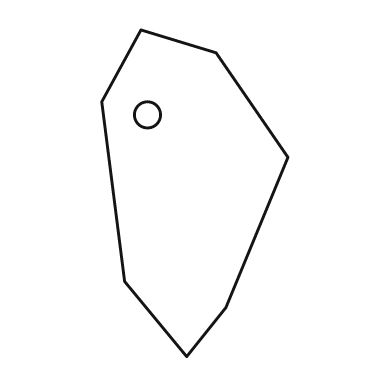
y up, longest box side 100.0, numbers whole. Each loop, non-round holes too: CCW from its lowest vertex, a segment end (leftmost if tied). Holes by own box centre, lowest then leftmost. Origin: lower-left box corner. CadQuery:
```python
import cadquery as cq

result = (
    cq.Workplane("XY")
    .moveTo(26.0, 0.0)
    .lineTo(38.0, 15.0)
    .lineTo(57.0, 61.0)
    .lineTo(35.0, 93.0)
    .lineTo(12.0, 100.0)
    .lineTo(0.0, 78.0)
    .lineTo(7.0, 23.0)
    .close()
    .moveTo(14.0, 74.0)
    .circle(4.0)
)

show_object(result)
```